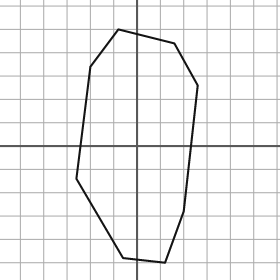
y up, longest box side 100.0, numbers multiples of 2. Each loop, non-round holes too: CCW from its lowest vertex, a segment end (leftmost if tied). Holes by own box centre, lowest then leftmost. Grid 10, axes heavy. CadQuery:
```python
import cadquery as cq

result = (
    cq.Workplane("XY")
    .moveTo(12.0, -50.0)
    .lineTo(20.0, -28.0)
    .lineTo(26.0, 26.0)
    .lineTo(16.0, 44.0)
    .lineTo(-8.0, 50.0)
    .lineTo(-20.0, 34.0)
    .lineTo(-26.0, -14.0)
    .lineTo(-6.0, -48.0)
    .close()
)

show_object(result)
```